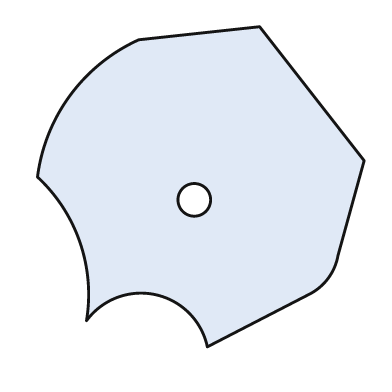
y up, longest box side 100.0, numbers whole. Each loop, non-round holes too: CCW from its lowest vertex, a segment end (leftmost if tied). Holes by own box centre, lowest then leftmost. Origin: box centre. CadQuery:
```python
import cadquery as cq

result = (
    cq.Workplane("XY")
    .moveTo(2.0, -49.0)
    .lineTo(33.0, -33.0)
    .threePointArc((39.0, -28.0), (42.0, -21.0))
    .lineTo(50.0, 8.0)
    .lineTo(18.0, 49.0)
    .lineTo(-19.0, 45.0)
    .threePointArc((-40.0, 28.0), (-50.0, 3.0))
    .threePointArc((-37.0, -17.0), (-35.0, -41.0))
    .threePointArc((-14.0, -33.0), (2.0, -49.0))
    .close()
    .moveTo(-2.0, -4.0)
    .circle(5.0)
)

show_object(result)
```